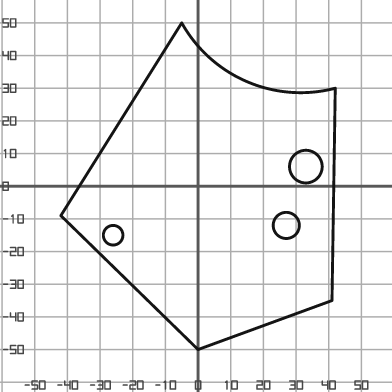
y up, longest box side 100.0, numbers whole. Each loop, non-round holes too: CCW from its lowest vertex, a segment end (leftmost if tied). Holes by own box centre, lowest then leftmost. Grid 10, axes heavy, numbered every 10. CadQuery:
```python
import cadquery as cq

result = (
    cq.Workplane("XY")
    .moveTo(0.0, -50.0)
    .lineTo(41.0, -35.0)
    .lineTo(42.0, 30.0)
    .threePointArc((15.0, 32.0), (-5.0, 50.0))
    .lineTo(-42.0, -9.0)
    .close()
    .moveTo(-26.0, -15.0)
    .circle(3.0)
    .moveTo(27.0, -12.0)
    .circle(4.0)
    .moveTo(33.0, 6.0)
    .circle(5.0)
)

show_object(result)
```